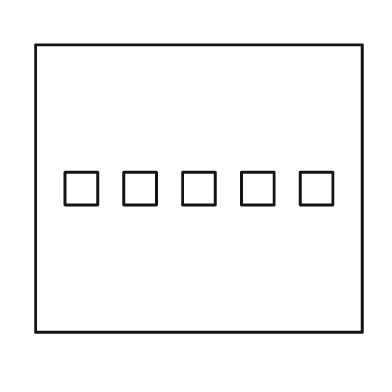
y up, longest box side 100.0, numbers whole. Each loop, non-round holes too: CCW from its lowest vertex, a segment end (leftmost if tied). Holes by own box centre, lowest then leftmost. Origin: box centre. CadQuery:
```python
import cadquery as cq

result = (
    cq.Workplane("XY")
    .moveTo(-50.0, -44.0)
    .lineTo(50.0, -44.0)
    .lineTo(50.0, 44.0)
    .lineTo(-50.0, 44.0)
    .close()
    .moveTo(-41.0, -5.0)
    .lineTo(-31.0, -5.0)
    .lineTo(-31.0, 5.0)
    .lineTo(-41.0, 5.0)
    .close()
    .moveTo(-23.0, -5.0)
    .lineTo(-13.0, -5.0)
    .lineTo(-13.0, 5.0)
    .lineTo(-23.0, 5.0)
    .close()
    .moveTo(-5.0, -5.0)
    .lineTo(5.0, -5.0)
    .lineTo(5.0, 5.0)
    .lineTo(-5.0, 5.0)
    .close()
    .moveTo(13.0, -5.0)
    .lineTo(23.0, -5.0)
    .lineTo(23.0, 5.0)
    .lineTo(13.0, 5.0)
    .close()
    .moveTo(31.0, -5.0)
    .lineTo(41.0, -5.0)
    .lineTo(41.0, 5.0)
    .lineTo(31.0, 5.0)
    .close()
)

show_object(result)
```